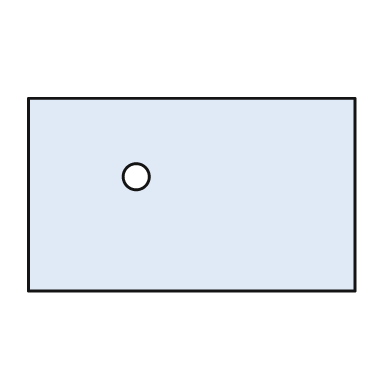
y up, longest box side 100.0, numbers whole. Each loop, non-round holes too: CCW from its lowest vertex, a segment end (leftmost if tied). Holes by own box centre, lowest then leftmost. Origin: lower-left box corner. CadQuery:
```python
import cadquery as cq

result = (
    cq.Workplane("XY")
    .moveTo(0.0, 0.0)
    .lineTo(100.0, 0.0)
    .lineTo(100.0, 59.0)
    .lineTo(0.0, 59.0)
    .close()
    .moveTo(33.0, 35.0)
    .circle(4.0)
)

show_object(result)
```